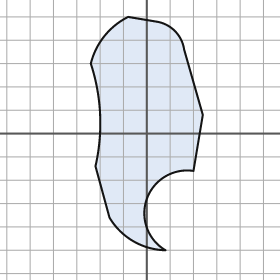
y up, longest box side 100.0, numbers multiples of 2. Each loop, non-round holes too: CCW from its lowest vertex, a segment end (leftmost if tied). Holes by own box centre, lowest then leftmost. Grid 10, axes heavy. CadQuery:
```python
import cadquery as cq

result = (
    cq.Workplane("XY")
    .moveTo(8.0, -50.0)
    .threePointArc((0.0, -28.0), (20.0, -16.0))
    .lineTo(24.0, 8.0)
    .lineTo(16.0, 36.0)
    .threePointArc((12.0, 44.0), (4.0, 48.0))
    .lineTo(-8.0, 50.0)
    .threePointArc((-18.0, 42.0), (-24.0, 30.0))
    .threePointArc((-20.0, 8.0), (-22.0, -14.0))
    .lineTo(-16.0, -36.0)
    .threePointArc((-6.0, -46.0), (8.0, -50.0))
    .close()
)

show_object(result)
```